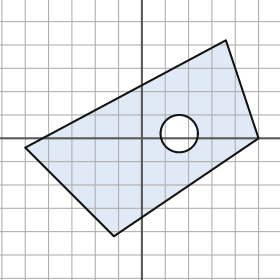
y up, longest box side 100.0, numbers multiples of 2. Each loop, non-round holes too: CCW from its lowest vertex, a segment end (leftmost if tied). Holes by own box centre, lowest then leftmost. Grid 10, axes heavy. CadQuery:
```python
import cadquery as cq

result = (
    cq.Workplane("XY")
    .moveTo(-12.0, -42.0)
    .lineTo(50.0, 0.0)
    .lineTo(36.0, 42.0)
    .lineTo(-50.0, -4.0)
    .close()
    .moveTo(16.0, 2.0)
    .circle(8.0)
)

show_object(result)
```